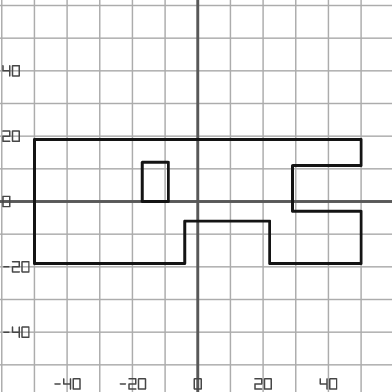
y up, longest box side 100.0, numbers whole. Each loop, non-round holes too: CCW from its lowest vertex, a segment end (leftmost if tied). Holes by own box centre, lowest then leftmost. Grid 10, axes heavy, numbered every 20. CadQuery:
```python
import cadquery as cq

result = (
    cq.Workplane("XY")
    .moveTo(-50.0, -19.0)
    .lineTo(-4.0, -19.0)
    .lineTo(-4.0, -6.0)
    .lineTo(22.0, -6.0)
    .lineTo(22.0, -19.0)
    .lineTo(50.0, -19.0)
    .lineTo(50.0, -3.0)
    .lineTo(29.0, -3.0)
    .lineTo(29.0, 11.0)
    .lineTo(50.0, 11.0)
    .lineTo(50.0, 19.0)
    .lineTo(-50.0, 19.0)
    .close()
    .moveTo(-17.0, 0.0)
    .lineTo(-9.0, 0.0)
    .lineTo(-9.0, 12.0)
    .lineTo(-17.0, 12.0)
    .close()
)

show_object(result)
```